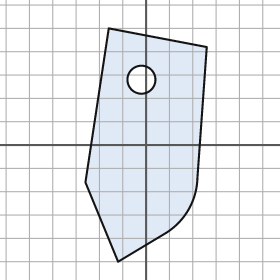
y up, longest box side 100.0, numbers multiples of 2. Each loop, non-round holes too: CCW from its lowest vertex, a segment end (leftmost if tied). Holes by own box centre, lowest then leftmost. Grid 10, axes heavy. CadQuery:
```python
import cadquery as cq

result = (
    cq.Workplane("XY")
    .moveTo(-12.0, -50.0)
    .lineTo(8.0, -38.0)
    .threePointArc((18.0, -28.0), (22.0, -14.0))
    .lineTo(26.0, 42.0)
    .lineTo(-16.0, 50.0)
    .lineTo(-26.0, -16.0)
    .close()
    .moveTo(-2.0, 28.0)
    .circle(6.0)
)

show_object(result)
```